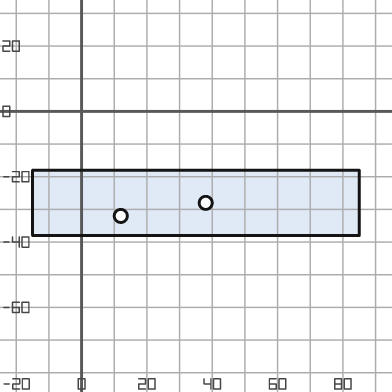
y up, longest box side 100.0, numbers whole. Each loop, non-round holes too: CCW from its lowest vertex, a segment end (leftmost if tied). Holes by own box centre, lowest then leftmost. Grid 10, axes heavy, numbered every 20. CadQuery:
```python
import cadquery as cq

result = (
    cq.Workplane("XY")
    .moveTo(-15.0, -38.0)
    .lineTo(85.0, -38.0)
    .lineTo(85.0, -18.0)
    .lineTo(-15.0, -18.0)
    .close()
    .moveTo(12.0, -32.0)
    .circle(2.0)
    .moveTo(38.0, -28.0)
    .circle(2.0)
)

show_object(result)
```